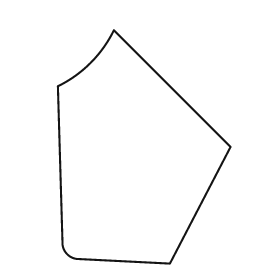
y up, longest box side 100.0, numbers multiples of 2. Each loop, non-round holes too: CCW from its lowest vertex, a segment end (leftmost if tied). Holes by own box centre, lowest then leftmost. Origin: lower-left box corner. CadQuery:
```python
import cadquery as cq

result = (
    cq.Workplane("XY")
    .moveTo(48.0, 0.0)
    .lineTo(74.0, 50.0)
    .lineTo(24.0, 100.0)
    .threePointArc((14.0, 86.0), (0.0, 76.0))
    .lineTo(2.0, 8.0)
    .threePointArc((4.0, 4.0), (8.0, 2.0))
    .close()
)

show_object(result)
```